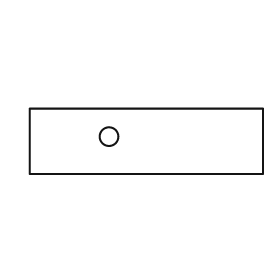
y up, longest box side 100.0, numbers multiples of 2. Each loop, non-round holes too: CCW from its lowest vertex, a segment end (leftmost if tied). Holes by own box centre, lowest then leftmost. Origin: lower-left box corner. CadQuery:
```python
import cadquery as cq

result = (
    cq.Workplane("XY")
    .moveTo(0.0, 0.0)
    .lineTo(100.0, 0.0)
    .lineTo(100.0, 28.0)
    .lineTo(0.0, 28.0)
    .close()
    .moveTo(34.0, 16.0)
    .circle(4.0)
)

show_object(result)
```